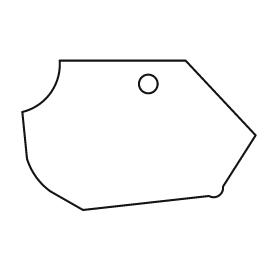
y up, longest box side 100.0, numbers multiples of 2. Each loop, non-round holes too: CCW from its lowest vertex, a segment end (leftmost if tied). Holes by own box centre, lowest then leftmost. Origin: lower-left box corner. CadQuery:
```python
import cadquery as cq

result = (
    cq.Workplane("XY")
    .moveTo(26.0, 0.0)
    .lineTo(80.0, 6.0)
    .threePointArc((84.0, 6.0), (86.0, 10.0))
    .lineTo(100.0, 32.0)
    .lineTo(70.0, 64.0)
    .lineTo(16.0, 64.0)
    .threePointArc((12.0, 50.0), (0.0, 42.0))
    .lineTo(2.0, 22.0)
    .threePointArc((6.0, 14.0), (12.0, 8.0))
    .close()
    .moveTo(54.0, 54.0)
    .circle(4.0)
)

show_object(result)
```